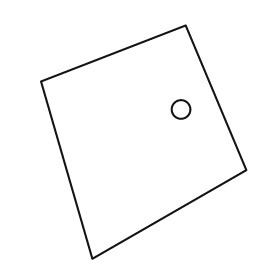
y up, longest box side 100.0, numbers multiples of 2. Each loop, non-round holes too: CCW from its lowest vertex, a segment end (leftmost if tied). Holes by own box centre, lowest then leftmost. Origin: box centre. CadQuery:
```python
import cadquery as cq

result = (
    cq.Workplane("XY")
    .moveTo(-22.0, -50.0)
    .lineTo(44.0, -12.0)
    .lineTo(18.0, 50.0)
    .lineTo(-44.0, 26.0)
    .close()
    .moveTo(16.0, 14.0)
    .circle(4.0)
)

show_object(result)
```